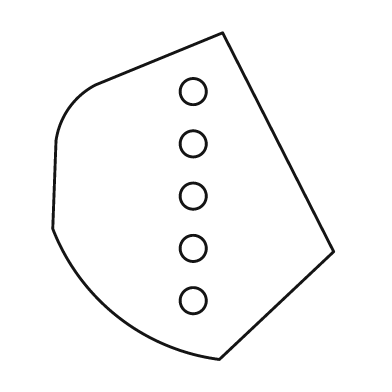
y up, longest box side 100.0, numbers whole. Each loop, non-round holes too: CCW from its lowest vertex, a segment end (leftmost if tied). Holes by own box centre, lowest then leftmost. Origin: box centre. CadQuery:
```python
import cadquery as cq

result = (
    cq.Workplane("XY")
    .moveTo(8.0, -50.0)
    .lineTo(43.0, -17.0)
    .lineTo(9.0, 50.0)
    .lineTo(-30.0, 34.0)
    .threePointArc((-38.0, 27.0), (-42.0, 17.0))
    .lineTo(-43.0, -10.0)
    .threePointArc((-23.0, -37.0), (8.0, -50.0))
    .close()
    .moveTo(0.0, -32.0)
    .circle(4.0)
    .moveTo(0.0, -16.0)
    .circle(4.0)
    .moveTo(0.0, 0.0)
    .circle(4.0)
    .moveTo(0.0, 16.0)
    .circle(4.0)
    .moveTo(0.0, 32.0)
    .circle(4.0)
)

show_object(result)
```